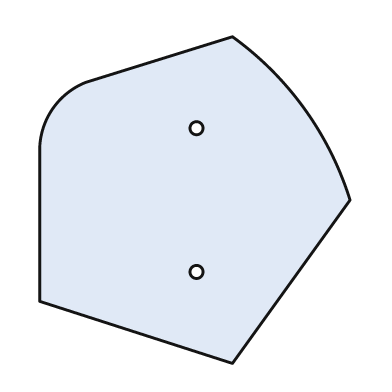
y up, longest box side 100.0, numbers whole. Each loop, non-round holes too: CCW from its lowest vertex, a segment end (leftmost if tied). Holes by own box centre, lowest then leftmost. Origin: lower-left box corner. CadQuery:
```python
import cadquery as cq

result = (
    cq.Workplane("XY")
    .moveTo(59.0, 0.0)
    .lineTo(95.0, 50.0)
    .threePointArc((81.0, 78.0), (59.0, 100.0))
    .lineTo(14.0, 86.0)
    .threePointArc((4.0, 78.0), (0.0, 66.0))
    .lineTo(0.0, 19.0)
    .close()
    .moveTo(48.0, 28.0)
    .circle(2.0)
    .moveTo(48.0, 72.0)
    .circle(2.0)
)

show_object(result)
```